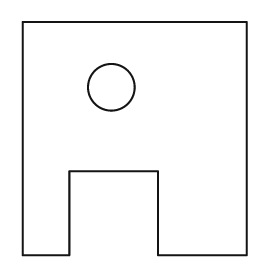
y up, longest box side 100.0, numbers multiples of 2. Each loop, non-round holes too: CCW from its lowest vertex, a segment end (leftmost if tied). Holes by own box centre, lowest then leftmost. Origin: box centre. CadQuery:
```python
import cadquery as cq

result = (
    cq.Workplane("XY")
    .moveTo(-48.0, -50.0)
    .lineTo(-28.0, -50.0)
    .lineTo(-28.0, -14.0)
    .lineTo(10.0, -14.0)
    .lineTo(10.0, -50.0)
    .lineTo(48.0, -50.0)
    .lineTo(48.0, 50.0)
    .lineTo(-48.0, 50.0)
    .close()
    .moveTo(-10.0, 22.0)
    .circle(10.0)
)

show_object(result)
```